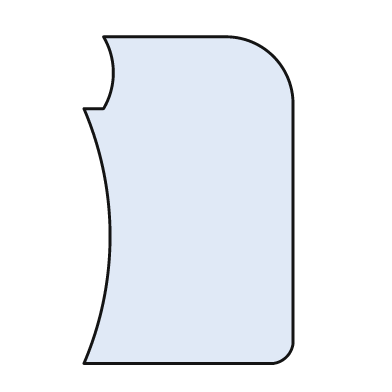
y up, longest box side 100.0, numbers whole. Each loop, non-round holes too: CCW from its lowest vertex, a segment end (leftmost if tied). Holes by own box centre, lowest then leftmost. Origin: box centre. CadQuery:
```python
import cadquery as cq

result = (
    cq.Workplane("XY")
    .moveTo(-32.0, -50.0)
    .lineTo(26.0, -50.0)
    .threePointArc((30.0, -48.0), (32.0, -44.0))
    .lineTo(32.0, 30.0)
    .threePointArc((26.0, 44.0), (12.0, 50.0))
    .lineTo(-26.0, 50.0)
    .threePointArc((-23.0, 39.0), (-26.0, 28.0))
    .lineTo(-32.0, 28.0)
    .threePointArc((-24.0, -11.0), (-32.0, -50.0))
    .close()
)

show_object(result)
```